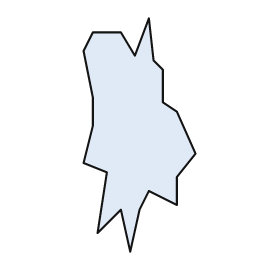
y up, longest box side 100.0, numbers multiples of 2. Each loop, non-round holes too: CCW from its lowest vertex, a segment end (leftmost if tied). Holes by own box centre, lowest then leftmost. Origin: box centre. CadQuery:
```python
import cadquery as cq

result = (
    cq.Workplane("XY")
    .moveTo(-4.0, -50.0)
    .lineTo(0.0, -32.0)
    .lineTo(4.0, -24.0)
    .lineTo(16.0, -30.0)
    .lineTo(16.0, -18.0)
    .lineTo(24.0, -8.0)
    .lineTo(16.0, 10.0)
    .lineTo(10.0, 14.0)
    .lineTo(10.0, 28.0)
    .lineTo(6.0, 32.0)
    .lineTo(4.0, 50.0)
    .lineTo(-2.0, 34.0)
    .lineTo(-8.0, 44.0)
    .lineTo(-20.0, 44.0)
    .lineTo(-24.0, 36.0)
    .lineTo(-20.0, 16.0)
    .lineTo(-20.0, 4.0)
    .lineTo(-24.0, -12.0)
    .lineTo(-14.0, -16.0)
    .lineTo(-18.0, -42.0)
    .lineTo(-8.0, -32.0)
    .close()
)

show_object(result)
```